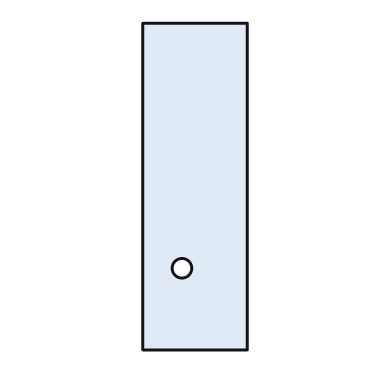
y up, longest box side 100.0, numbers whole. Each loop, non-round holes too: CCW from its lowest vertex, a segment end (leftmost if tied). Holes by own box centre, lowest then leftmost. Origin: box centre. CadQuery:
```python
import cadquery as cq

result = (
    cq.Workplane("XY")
    .moveTo(-16.0, -50.0)
    .lineTo(16.0, -50.0)
    .lineTo(16.0, 50.0)
    .lineTo(-16.0, 50.0)
    .close()
    .moveTo(-4.0, -25.0)
    .circle(3.0)
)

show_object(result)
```